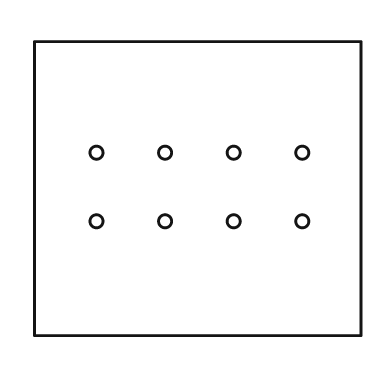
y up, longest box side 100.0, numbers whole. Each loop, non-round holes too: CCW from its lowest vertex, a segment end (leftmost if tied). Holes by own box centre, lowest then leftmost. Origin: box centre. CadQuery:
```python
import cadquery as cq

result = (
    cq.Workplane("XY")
    .moveTo(-50.0, -45.0)
    .lineTo(50.0, -45.0)
    .lineTo(50.0, 45.0)
    .lineTo(-50.0, 45.0)
    .close()
    .moveTo(-31.0, -10.0)
    .circle(2.0)
    .moveTo(-10.0, -10.0)
    .circle(2.0)
    .moveTo(11.0, -10.0)
    .circle(2.0)
    .moveTo(32.0, -10.0)
    .circle(2.0)
    .moveTo(-31.0, 11.0)
    .circle(2.0)
    .moveTo(-10.0, 11.0)
    .circle(2.0)
    .moveTo(11.0, 11.0)
    .circle(2.0)
    .moveTo(32.0, 11.0)
    .circle(2.0)
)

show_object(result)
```